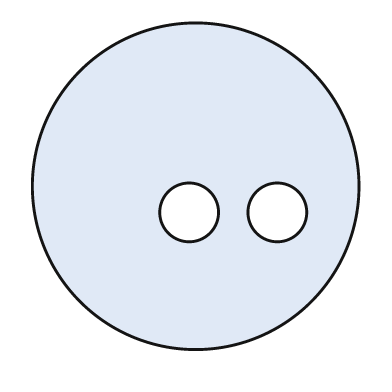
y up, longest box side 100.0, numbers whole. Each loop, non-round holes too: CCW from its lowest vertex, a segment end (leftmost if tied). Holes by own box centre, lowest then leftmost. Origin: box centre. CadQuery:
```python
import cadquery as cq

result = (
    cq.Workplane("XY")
    .moveTo(0.0, 0.0)
    .circle(50.0)
    .moveTo(-2.0, -8.0)
    .circle(9.0)
    .moveTo(25.0, -8.0)
    .circle(9.0)
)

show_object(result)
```